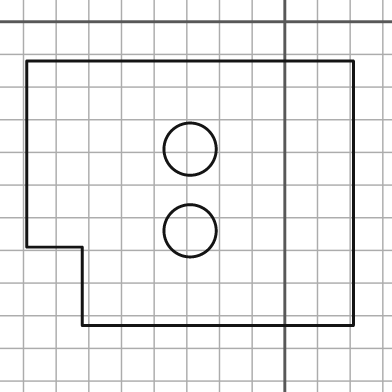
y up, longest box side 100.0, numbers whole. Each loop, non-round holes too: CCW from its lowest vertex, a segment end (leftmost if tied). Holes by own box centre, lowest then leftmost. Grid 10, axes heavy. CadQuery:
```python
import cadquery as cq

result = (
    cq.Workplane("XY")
    .moveTo(-62.0, -93.0)
    .lineTo(21.0, -93.0)
    .lineTo(21.0, -12.0)
    .lineTo(-79.0, -12.0)
    .lineTo(-79.0, -69.0)
    .lineTo(-62.0, -69.0)
    .close()
    .moveTo(-29.0, -64.0)
    .circle(8.0)
    .moveTo(-29.0, -39.0)
    .circle(8.0)
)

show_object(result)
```